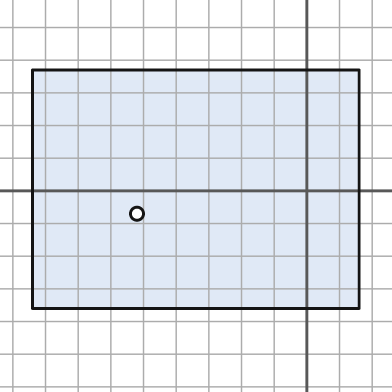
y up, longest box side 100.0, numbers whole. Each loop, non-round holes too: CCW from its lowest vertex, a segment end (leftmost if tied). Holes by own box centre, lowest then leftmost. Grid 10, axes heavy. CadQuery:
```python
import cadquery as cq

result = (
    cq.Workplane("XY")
    .moveTo(-84.0, -36.0)
    .lineTo(16.0, -36.0)
    .lineTo(16.0, 37.0)
    .lineTo(-84.0, 37.0)
    .close()
    .moveTo(-52.0, -7.0)
    .circle(2.0)
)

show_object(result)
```